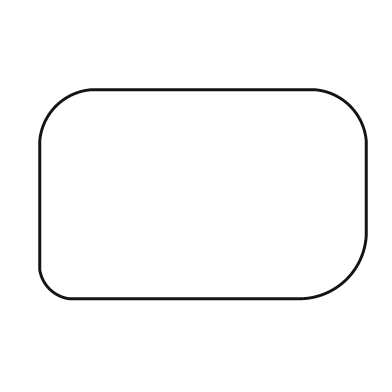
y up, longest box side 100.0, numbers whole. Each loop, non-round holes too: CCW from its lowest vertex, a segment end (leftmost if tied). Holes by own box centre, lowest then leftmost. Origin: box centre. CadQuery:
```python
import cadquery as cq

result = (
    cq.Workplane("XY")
    .moveTo(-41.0, -32.0)
    .lineTo(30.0, -32.0)
    .threePointArc((44.0, -26.0), (50.0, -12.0))
    .lineTo(50.0, 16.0)
    .threePointArc((45.0, 27.0), (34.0, 32.0))
    .lineTo(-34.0, 32.0)
    .threePointArc((-45.0, 27.0), (-50.0, 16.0))
    .lineTo(-50.0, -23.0)
    .threePointArc((-47.0, -29.0), (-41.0, -32.0))
    .close()
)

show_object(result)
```